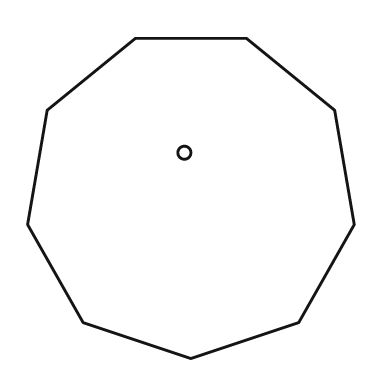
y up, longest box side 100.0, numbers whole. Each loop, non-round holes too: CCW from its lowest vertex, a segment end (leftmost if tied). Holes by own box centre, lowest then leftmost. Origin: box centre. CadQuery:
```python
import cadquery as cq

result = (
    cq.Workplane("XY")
    .moveTo(0.0, -49.0)
    .lineTo(33.0, -38.0)
    .lineTo(50.0, -8.0)
    .lineTo(44.0, 27.0)
    .lineTo(17.0, 49.0)
    .lineTo(-17.0, 49.0)
    .lineTo(-44.0, 27.0)
    .lineTo(-50.0, -8.0)
    .lineTo(-33.0, -38.0)
    .close()
    .moveTo(-2.0, 14.0)
    .circle(2.0)
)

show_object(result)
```